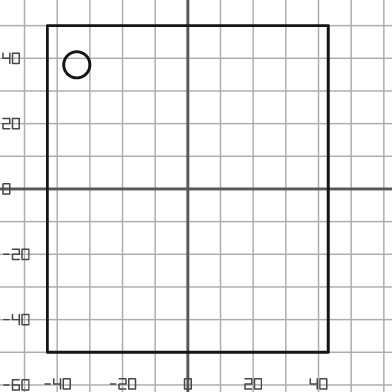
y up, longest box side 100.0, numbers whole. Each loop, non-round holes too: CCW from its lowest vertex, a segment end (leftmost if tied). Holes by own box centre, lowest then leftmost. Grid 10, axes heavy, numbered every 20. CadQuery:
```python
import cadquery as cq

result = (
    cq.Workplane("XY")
    .moveTo(-43.0, -50.0)
    .lineTo(43.0, -50.0)
    .lineTo(43.0, 50.0)
    .lineTo(-43.0, 50.0)
    .close()
    .moveTo(-34.0, 38.0)
    .circle(4.0)
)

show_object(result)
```